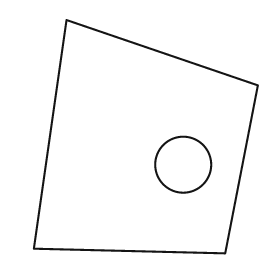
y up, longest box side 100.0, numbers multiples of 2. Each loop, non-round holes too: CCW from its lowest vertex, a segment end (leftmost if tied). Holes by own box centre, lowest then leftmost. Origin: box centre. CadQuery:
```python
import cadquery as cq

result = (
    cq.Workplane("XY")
    .moveTo(34.0, -50.0)
    .lineTo(48.0, 22.0)
    .lineTo(-34.0, 50.0)
    .lineTo(-48.0, -48.0)
    .close()
    .moveTo(16.0, -12.0)
    .circle(12.0)
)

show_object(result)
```